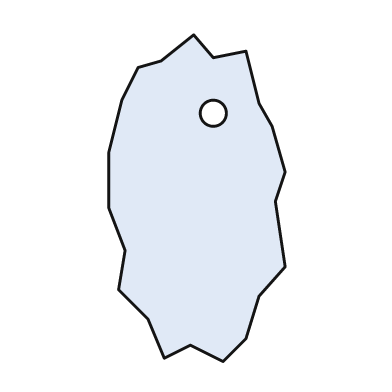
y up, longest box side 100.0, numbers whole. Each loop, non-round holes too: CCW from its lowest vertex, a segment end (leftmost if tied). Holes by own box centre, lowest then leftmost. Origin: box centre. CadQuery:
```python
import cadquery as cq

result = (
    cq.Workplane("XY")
    .moveTo(8.0, -50.0)
    .lineTo(15.0, -43.0)
    .lineTo(19.0, -30.0)
    .lineTo(27.0, -21.0)
    .lineTo(24.0, -1.0)
    .lineTo(27.0, 8.0)
    .lineTo(23.0, 22.0)
    .lineTo(19.0, 29.0)
    .lineTo(15.0, 45.0)
    .lineTo(5.0, 43.0)
    .lineTo(-1.0, 50.0)
    .lineTo(-11.0, 42.0)
    .lineTo(-18.0, 40.0)
    .lineTo(-23.0, 30.0)
    .lineTo(-27.0, 14.0)
    .lineTo(-27.0, -3.0)
    .lineTo(-22.0, -16.0)
    .lineTo(-24.0, -28.0)
    .lineTo(-15.0, -37.0)
    .lineTo(-10.0, -49.0)
    .lineTo(-2.0, -45.0)
    .close()
    .moveTo(5.0, 26.0)
    .circle(4.0)
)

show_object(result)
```